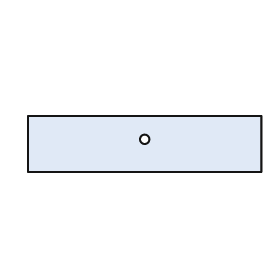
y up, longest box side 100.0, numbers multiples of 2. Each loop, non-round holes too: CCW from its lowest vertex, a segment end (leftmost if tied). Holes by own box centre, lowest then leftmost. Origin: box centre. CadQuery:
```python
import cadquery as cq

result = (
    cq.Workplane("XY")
    .moveTo(-50.0, -12.0)
    .lineTo(50.0, -12.0)
    .lineTo(50.0, 12.0)
    .lineTo(-50.0, 12.0)
    .close()
    .moveTo(0.0, 2.0)
    .circle(2.0)
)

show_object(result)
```